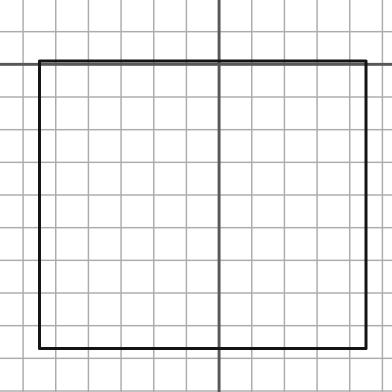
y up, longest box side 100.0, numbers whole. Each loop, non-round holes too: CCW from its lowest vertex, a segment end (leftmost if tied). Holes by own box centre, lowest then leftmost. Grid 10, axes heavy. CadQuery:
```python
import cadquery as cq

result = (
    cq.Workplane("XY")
    .moveTo(-55.0, -87.0)
    .lineTo(45.0, -87.0)
    .lineTo(45.0, 1.0)
    .lineTo(-55.0, 1.0)
    .close()
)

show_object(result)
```